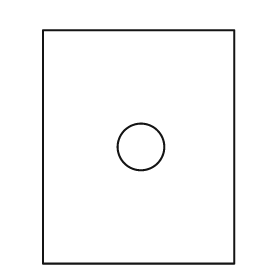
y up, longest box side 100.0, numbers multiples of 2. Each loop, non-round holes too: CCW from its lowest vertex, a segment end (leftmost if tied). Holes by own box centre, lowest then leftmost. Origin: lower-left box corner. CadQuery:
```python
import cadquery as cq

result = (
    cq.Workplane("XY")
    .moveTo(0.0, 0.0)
    .lineTo(82.0, 0.0)
    .lineTo(82.0, 100.0)
    .lineTo(0.0, 100.0)
    .close()
    .moveTo(42.0, 50.0)
    .circle(10.0)
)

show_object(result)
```